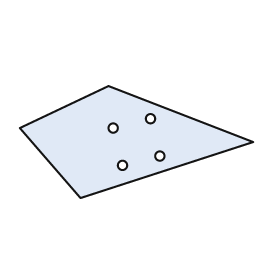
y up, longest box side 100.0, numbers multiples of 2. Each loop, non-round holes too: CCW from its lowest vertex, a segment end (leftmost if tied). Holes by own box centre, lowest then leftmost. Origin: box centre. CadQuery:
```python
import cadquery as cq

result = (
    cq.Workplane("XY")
    .moveTo(-24.0, -24.0)
    .lineTo(50.0, 0.0)
    .lineTo(-12.0, 24.0)
    .lineTo(-50.0, 6.0)
    .close()
    .moveTo(-6.0, -10.0)
    .circle(2.0)
    .moveTo(10.0, -6.0)
    .circle(2.0)
    .moveTo(-10.0, 6.0)
    .circle(2.0)
    .moveTo(6.0, 10.0)
    .circle(2.0)
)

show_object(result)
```